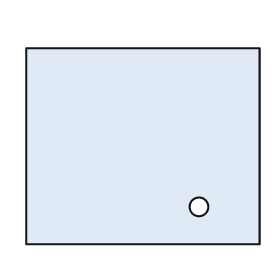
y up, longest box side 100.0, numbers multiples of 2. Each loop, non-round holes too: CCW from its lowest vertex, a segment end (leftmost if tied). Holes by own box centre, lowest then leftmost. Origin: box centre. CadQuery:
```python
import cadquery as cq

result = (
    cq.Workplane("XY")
    .moveTo(-50.0, -42.0)
    .lineTo(50.0, -42.0)
    .lineTo(50.0, 42.0)
    .lineTo(-50.0, 42.0)
    .close()
    .moveTo(24.0, -26.0)
    .circle(4.0)
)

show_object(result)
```